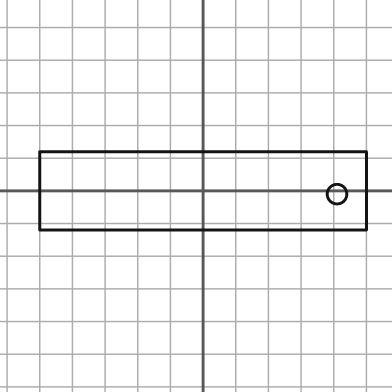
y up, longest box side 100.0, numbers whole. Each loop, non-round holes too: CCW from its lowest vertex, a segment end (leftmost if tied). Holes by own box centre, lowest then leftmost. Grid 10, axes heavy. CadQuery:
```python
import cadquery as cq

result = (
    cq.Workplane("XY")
    .moveTo(-50.0, -12.0)
    .lineTo(50.0, -12.0)
    .lineTo(50.0, 12.0)
    .lineTo(-50.0, 12.0)
    .close()
    .moveTo(41.0, -1.0)
    .circle(3.0)
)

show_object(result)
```